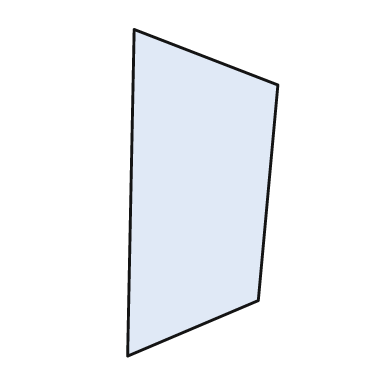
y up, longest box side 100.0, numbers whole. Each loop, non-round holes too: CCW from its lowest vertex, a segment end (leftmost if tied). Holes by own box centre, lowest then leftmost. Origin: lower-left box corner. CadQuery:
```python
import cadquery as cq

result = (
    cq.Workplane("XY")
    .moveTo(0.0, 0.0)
    .lineTo(40.0, 17.0)
    .lineTo(46.0, 83.0)
    .lineTo(2.0, 100.0)
    .close()
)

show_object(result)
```